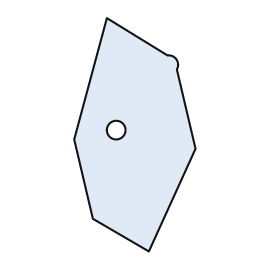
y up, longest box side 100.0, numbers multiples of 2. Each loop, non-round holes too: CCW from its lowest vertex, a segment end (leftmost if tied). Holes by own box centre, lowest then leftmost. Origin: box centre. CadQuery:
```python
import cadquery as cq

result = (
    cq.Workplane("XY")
    .moveTo(6.0, -50.0)
    .lineTo(26.0, -6.0)
    .lineTo(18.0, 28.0)
    .threePointArc((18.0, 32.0), (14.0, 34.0))
    .lineTo(-12.0, 50.0)
    .lineTo(-26.0, -2.0)
    .lineTo(-18.0, -36.0)
    .close()
    .moveTo(-8.0, 2.0)
    .circle(4.0)
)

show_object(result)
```